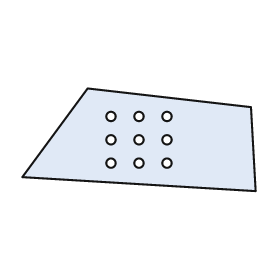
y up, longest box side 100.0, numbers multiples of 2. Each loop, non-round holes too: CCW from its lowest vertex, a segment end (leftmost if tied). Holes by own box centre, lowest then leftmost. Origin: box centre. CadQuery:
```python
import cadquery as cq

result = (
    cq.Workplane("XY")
    .moveTo(50.0, -22.0)
    .lineTo(48.0, 14.0)
    .lineTo(-22.0, 22.0)
    .lineTo(-50.0, -16.0)
    .close()
    .moveTo(-12.0, -10.0)
    .circle(2.0)
    .moveTo(0.0, -10.0)
    .circle(2.0)
    .moveTo(12.0, -10.0)
    .circle(2.0)
    .moveTo(-12.0, 0.0)
    .circle(2.0)
    .moveTo(0.0, 0.0)
    .circle(2.0)
    .moveTo(12.0, 0.0)
    .circle(2.0)
    .moveTo(-12.0, 10.0)
    .circle(2.0)
    .moveTo(0.0, 10.0)
    .circle(2.0)
    .moveTo(12.0, 10.0)
    .circle(2.0)
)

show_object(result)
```